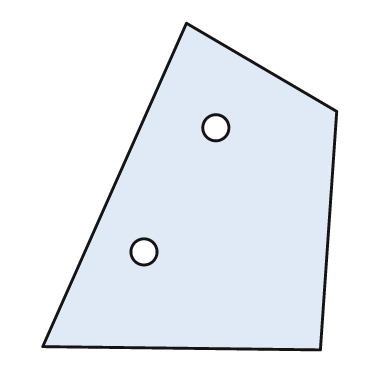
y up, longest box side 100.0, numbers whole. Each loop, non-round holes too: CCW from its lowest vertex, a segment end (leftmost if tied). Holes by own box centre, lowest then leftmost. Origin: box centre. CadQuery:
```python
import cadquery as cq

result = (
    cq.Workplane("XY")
    .moveTo(40.0, -50.0)
    .lineTo(45.0, 23.0)
    .lineTo(-1.0, 50.0)
    .lineTo(-45.0, -49.0)
    .close()
    .moveTo(-14.0, -20.0)
    .circle(4.0)
    .moveTo(8.0, 18.0)
    .circle(4.0)
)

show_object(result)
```